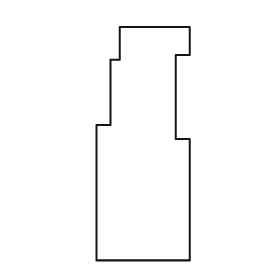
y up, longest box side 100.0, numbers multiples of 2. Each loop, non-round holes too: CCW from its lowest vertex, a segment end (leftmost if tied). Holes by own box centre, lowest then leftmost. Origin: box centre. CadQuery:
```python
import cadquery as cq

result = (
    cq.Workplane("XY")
    .moveTo(-20.0, -50.0)
    .lineTo(20.0, -50.0)
    .lineTo(20.0, 2.0)
    .lineTo(14.0, 2.0)
    .lineTo(14.0, 38.0)
    .lineTo(20.0, 38.0)
    .lineTo(20.0, 50.0)
    .lineTo(-10.0, 50.0)
    .lineTo(-10.0, 36.0)
    .lineTo(-14.0, 36.0)
    .lineTo(-14.0, 8.0)
    .lineTo(-20.0, 8.0)
    .close()
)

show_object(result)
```